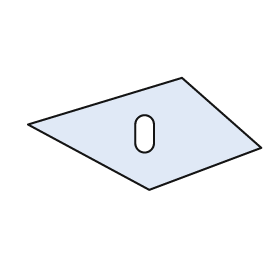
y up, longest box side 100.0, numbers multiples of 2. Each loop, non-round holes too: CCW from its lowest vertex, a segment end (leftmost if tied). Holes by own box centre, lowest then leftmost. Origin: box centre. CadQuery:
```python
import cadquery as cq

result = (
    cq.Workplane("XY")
    .moveTo(2.0, -24.0)
    .lineTo(50.0, -6.0)
    .lineTo(16.0, 24.0)
    .lineTo(-50.0, 4.0)
    .close()
    .moveTo(-4.0, -4.0)
    .threePointArc((0.0, -8.0), (4.0, -4.0))
    .lineTo(4.0, 4.0)
    .threePointArc((0.0, 8.0), (-4.0, 4.0))
    .close()
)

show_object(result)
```